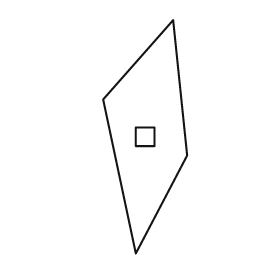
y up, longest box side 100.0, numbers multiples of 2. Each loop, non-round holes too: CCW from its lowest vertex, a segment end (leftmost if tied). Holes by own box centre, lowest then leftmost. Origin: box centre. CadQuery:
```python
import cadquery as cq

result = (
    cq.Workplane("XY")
    .moveTo(-4.0, -50.0)
    .lineTo(18.0, -8.0)
    .lineTo(12.0, 50.0)
    .lineTo(-18.0, 16.0)
    .close()
    .moveTo(-4.0, -4.0)
    .lineTo(4.0, -4.0)
    .lineTo(4.0, 4.0)
    .lineTo(-4.0, 4.0)
    .close()
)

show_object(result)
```